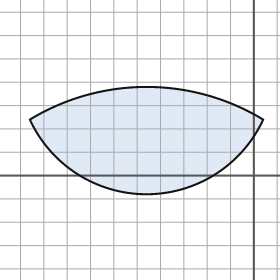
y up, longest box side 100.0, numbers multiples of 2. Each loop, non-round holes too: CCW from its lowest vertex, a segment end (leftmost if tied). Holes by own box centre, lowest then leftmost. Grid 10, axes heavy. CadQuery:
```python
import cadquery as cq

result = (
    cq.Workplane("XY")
    .moveTo(-96.0, 24.0)
    .threePointArc((-46.0, -8.0), (4.0, 24.0))
    .threePointArc((-46.0, 38.0), (-96.0, 24.0))
    .close()
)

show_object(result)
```